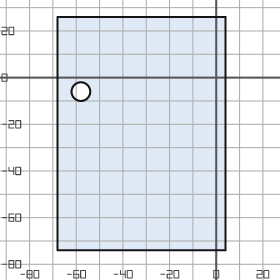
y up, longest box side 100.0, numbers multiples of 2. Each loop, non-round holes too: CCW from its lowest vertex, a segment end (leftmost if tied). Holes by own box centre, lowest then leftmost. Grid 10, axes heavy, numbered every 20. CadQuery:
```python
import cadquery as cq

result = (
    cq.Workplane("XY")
    .moveTo(-68.0, -74.0)
    .lineTo(4.0, -74.0)
    .lineTo(4.0, 26.0)
    .lineTo(-68.0, 26.0)
    .close()
    .moveTo(-58.0, -6.0)
    .circle(4.0)
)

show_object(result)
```